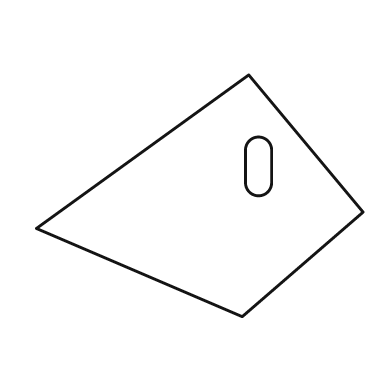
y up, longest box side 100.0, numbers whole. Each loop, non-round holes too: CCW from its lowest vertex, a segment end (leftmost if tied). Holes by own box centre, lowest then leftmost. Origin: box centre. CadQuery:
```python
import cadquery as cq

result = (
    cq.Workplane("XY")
    .moveTo(13.0, -37.0)
    .lineTo(50.0, -5.0)
    .lineTo(15.0, 37.0)
    .lineTo(-50.0, -10.0)
    .close()
    .moveTo(14.0, 4.0)
    .threePointArc((18.0, 0.0), (22.0, 4.0))
    .lineTo(22.0, 14.0)
    .threePointArc((18.0, 18.0), (14.0, 14.0))
    .close()
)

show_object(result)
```